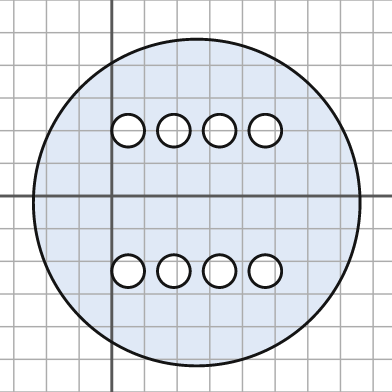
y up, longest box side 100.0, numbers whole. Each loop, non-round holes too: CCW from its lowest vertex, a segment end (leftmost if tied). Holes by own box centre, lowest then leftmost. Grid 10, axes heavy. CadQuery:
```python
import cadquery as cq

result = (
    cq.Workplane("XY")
    .moveTo(26.0, -2.0)
    .circle(50.0)
    .moveTo(5.0, -23.0)
    .circle(5.0)
    .moveTo(19.0, -23.0)
    .circle(5.0)
    .moveTo(33.0, -23.0)
    .circle(5.0)
    .moveTo(47.0, -23.0)
    .circle(5.0)
    .moveTo(5.0, 20.0)
    .circle(5.0)
    .moveTo(19.0, 20.0)
    .circle(5.0)
    .moveTo(33.0, 20.0)
    .circle(5.0)
    .moveTo(47.0, 20.0)
    .circle(5.0)
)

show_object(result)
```